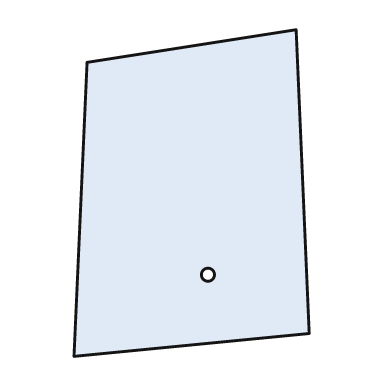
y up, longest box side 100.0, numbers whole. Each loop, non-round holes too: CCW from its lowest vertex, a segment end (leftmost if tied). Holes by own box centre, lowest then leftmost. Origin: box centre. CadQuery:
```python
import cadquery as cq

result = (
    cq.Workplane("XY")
    .moveTo(-36.0, -50.0)
    .lineTo(36.0, -43.0)
    .lineTo(32.0, 50.0)
    .lineTo(-32.0, 40.0)
    .close()
    .moveTo(5.0, -25.0)
    .circle(2.0)
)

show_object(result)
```